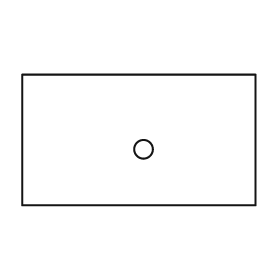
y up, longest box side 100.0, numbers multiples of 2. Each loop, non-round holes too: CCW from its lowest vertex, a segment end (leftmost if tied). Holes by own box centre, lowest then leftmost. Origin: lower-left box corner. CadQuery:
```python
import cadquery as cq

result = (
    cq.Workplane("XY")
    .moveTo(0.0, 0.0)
    .lineTo(100.0, 0.0)
    .lineTo(100.0, 56.0)
    .lineTo(0.0, 56.0)
    .close()
    .moveTo(52.0, 24.0)
    .circle(4.0)
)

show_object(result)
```